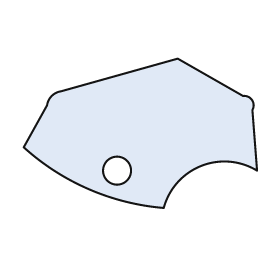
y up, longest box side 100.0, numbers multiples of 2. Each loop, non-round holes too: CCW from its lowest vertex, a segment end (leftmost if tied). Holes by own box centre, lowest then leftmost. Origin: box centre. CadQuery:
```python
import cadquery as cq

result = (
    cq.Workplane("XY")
    .moveTo(10.0, -32.0)
    .threePointArc((26.0, -14.0), (50.0, -16.0))
    .lineTo(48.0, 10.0)
    .threePointArc((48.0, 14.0), (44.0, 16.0))
    .lineTo(16.0, 32.0)
    .lineTo(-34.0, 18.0)
    .threePointArc((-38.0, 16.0), (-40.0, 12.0))
    .lineTo(-50.0, -6.0)
    .threePointArc((-22.0, -24.0), (10.0, -32.0))
    .close()
    .moveTo(-10.0, -16.0)
    .circle(6.0)
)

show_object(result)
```